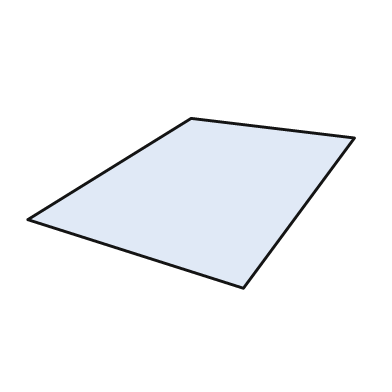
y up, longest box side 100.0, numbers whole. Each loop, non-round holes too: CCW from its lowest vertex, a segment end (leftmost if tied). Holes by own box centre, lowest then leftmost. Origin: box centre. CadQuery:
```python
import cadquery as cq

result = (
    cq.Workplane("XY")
    .moveTo(16.0, -26.0)
    .lineTo(50.0, 20.0)
    .lineTo(0.0, 26.0)
    .lineTo(-50.0, -5.0)
    .close()
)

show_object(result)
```